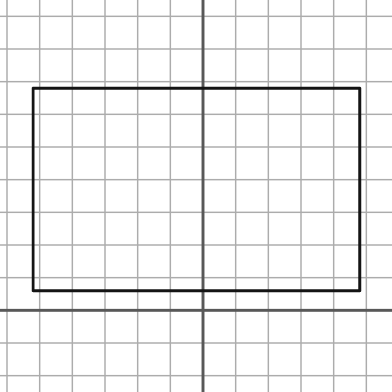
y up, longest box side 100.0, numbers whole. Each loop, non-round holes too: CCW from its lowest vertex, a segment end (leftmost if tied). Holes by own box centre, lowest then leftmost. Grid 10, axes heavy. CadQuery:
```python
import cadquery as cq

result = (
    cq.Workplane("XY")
    .moveTo(-52.0, 6.0)
    .lineTo(48.0, 6.0)
    .lineTo(48.0, 68.0)
    .lineTo(-52.0, 68.0)
    .close()
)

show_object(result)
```